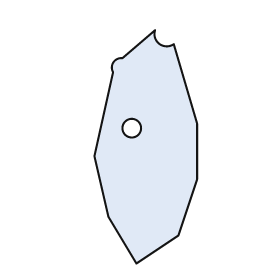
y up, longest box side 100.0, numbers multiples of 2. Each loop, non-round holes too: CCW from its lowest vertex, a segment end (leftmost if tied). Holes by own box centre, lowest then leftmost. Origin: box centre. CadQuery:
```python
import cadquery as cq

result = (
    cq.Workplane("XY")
    .moveTo(-4.0, -50.0)
    .lineTo(14.0, -38.0)
    .lineTo(22.0, -14.0)
    .lineTo(22.0, 10.0)
    .lineTo(12.0, 44.0)
    .threePointArc((6.0, 44.0), (4.0, 50.0))
    .lineTo(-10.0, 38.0)
    .threePointArc((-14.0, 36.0), (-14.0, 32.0))
    .lineTo(-22.0, -4.0)
    .lineTo(-16.0, -30.0)
    .close()
    .moveTo(-6.0, 8.0)
    .circle(4.0)
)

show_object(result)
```